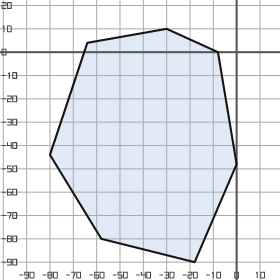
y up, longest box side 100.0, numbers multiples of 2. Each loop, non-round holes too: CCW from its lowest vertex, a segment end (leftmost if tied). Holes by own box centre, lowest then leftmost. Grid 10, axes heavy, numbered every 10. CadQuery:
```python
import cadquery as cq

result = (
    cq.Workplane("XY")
    .moveTo(-18.0, -90.0)
    .lineTo(0.0, -48.0)
    .lineTo(-8.0, 0.0)
    .lineTo(-30.0, 10.0)
    .lineTo(-64.0, 4.0)
    .lineTo(-80.0, -44.0)
    .lineTo(-58.0, -80.0)
    .close()
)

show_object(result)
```